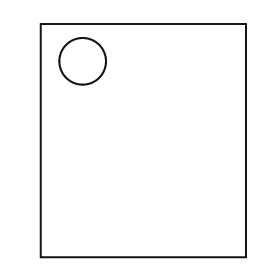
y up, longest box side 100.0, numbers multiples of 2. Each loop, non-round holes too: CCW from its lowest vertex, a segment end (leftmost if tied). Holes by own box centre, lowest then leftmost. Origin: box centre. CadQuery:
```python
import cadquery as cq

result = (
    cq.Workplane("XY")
    .moveTo(-44.0, -50.0)
    .lineTo(44.0, -50.0)
    .lineTo(44.0, 50.0)
    .lineTo(-44.0, 50.0)
    .close()
    .moveTo(-26.0, 34.0)
    .circle(10.0)
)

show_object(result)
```